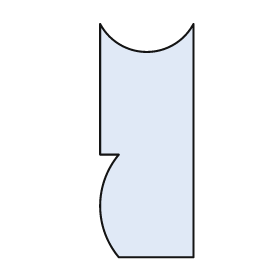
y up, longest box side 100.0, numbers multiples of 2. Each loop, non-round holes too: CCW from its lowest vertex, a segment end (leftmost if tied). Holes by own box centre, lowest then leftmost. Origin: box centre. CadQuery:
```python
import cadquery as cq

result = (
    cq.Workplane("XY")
    .moveTo(-12.0, -50.0)
    .lineTo(20.0, -50.0)
    .lineTo(20.0, 50.0)
    .threePointArc((0.0, 38.0), (-20.0, 50.0))
    .lineTo(-20.0, -6.0)
    .lineTo(-12.0, -6.0)
    .threePointArc((-20.0, -28.0), (-12.0, -50.0))
    .close()
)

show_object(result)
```